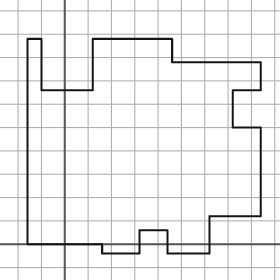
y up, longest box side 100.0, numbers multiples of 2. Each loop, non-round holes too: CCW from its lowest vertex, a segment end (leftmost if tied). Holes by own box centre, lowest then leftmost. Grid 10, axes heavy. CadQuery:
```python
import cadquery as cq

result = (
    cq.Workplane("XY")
    .moveTo(16.0, -4.0)
    .lineTo(32.0, -4.0)
    .lineTo(32.0, 6.0)
    .lineTo(44.0, 6.0)
    .lineTo(44.0, -4.0)
    .lineTo(62.0, -4.0)
    .lineTo(62.0, 12.0)
    .lineTo(84.0, 12.0)
    .lineTo(84.0, 50.0)
    .lineTo(72.0, 50.0)
    .lineTo(72.0, 66.0)
    .lineTo(84.0, 66.0)
    .lineTo(84.0, 78.0)
    .lineTo(46.0, 78.0)
    .lineTo(46.0, 88.0)
    .lineTo(12.0, 88.0)
    .lineTo(12.0, 66.0)
    .lineTo(-10.0, 66.0)
    .lineTo(-10.0, 88.0)
    .lineTo(-16.0, 88.0)
    .lineTo(-16.0, 0.0)
    .lineTo(16.0, 0.0)
    .close()
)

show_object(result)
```